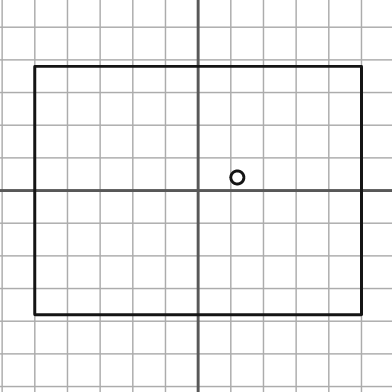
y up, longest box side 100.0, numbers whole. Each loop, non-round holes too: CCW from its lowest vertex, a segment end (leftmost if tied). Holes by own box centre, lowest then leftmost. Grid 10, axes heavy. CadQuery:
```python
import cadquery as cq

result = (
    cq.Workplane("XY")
    .moveTo(-50.0, -38.0)
    .lineTo(50.0, -38.0)
    .lineTo(50.0, 38.0)
    .lineTo(-50.0, 38.0)
    .close()
    .moveTo(12.0, 4.0)
    .circle(2.0)
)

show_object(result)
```